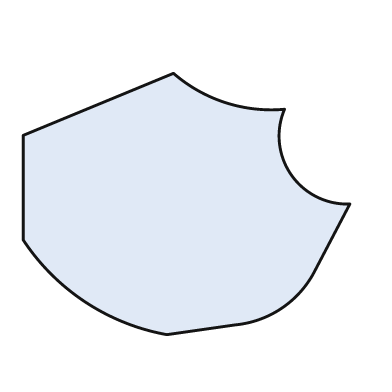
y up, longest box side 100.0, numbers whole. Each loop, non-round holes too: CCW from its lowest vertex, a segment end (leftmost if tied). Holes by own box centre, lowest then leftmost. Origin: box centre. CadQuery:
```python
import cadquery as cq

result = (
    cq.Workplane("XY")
    .moveTo(-6.0, -40.0)
    .lineTo(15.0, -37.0)
    .threePointArc((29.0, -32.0), (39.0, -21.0))
    .lineTo(50.0, 0.0)
    .threePointArc((32.0, 9.0), (30.0, 29.0))
    .threePointArc((12.0, 31.0), (-4.0, 40.0))
    .lineTo(-50.0, 21.0)
    .lineTo(-50.0, -11.0)
    .threePointArc((-31.0, -30.0), (-6.0, -40.0))
    .close()
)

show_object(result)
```